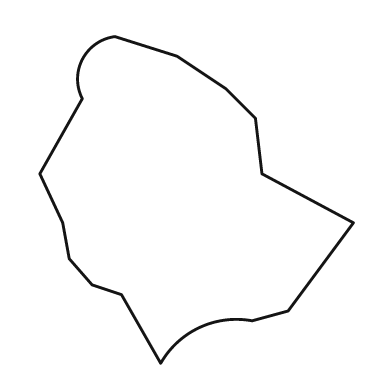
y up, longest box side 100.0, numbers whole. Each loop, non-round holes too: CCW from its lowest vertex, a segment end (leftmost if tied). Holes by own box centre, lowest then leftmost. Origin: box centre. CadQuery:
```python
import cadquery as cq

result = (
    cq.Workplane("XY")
    .moveTo(-11.0, -50.0)
    .threePointArc((1.0, -39.0), (17.0, -37.0))
    .lineTo(28.0, -34.0)
    .lineTo(48.0, -7.0)
    .lineTo(20.0, 8.0)
    .lineTo(18.0, 25.0)
    .lineTo(9.0, 34.0)
    .lineTo(-6.0, 44.0)
    .lineTo(-25.0, 50.0)
    .threePointArc((-35.0, 43.0), (-35.0, 31.0))
    .lineTo(-48.0, 8.0)
    .lineTo(-41.0, -7.0)
    .lineTo(-39.0, -18.0)
    .lineTo(-32.0, -26.0)
    .lineTo(-23.0, -29.0)
    .close()
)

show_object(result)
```